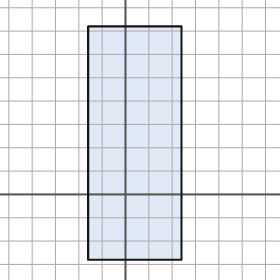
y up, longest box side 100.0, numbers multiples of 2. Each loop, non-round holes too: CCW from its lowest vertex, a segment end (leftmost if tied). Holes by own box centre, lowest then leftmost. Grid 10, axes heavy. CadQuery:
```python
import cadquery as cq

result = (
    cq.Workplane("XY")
    .moveTo(-16.0, -28.0)
    .lineTo(24.0, -28.0)
    .lineTo(24.0, 72.0)
    .lineTo(-16.0, 72.0)
    .close()
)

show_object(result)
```